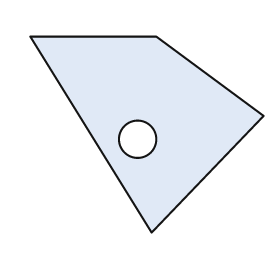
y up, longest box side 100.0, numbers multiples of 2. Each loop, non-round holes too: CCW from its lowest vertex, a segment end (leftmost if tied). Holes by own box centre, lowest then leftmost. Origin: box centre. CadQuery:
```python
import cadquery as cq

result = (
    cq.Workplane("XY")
    .moveTo(2.0, -42.0)
    .lineTo(50.0, 8.0)
    .lineTo(4.0, 42.0)
    .lineTo(-50.0, 42.0)
    .close()
    .moveTo(-4.0, -2.0)
    .circle(8.0)
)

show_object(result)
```